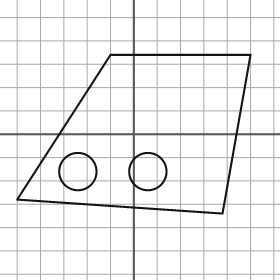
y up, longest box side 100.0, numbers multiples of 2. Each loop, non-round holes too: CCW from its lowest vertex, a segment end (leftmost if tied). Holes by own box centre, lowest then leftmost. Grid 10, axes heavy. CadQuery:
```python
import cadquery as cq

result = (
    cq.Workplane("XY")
    .moveTo(38.0, -34.0)
    .lineTo(50.0, 34.0)
    .lineTo(-10.0, 34.0)
    .lineTo(-50.0, -28.0)
    .close()
    .moveTo(-24.0, -16.0)
    .circle(8.0)
    .moveTo(6.0, -16.0)
    .circle(8.0)
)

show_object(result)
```